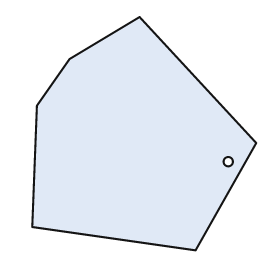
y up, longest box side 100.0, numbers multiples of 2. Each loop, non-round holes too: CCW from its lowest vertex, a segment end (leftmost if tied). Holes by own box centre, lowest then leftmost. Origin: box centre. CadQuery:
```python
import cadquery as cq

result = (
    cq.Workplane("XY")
    .moveTo(22.0, -50.0)
    .lineTo(48.0, -4.0)
    .lineTo(-2.0, 50.0)
    .lineTo(-32.0, 32.0)
    .lineTo(-46.0, 12.0)
    .lineTo(-48.0, -40.0)
    .close()
    .moveTo(36.0, -12.0)
    .circle(2.0)
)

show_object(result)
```